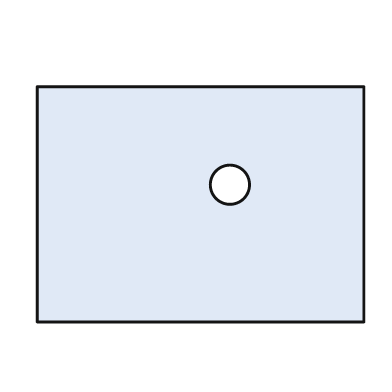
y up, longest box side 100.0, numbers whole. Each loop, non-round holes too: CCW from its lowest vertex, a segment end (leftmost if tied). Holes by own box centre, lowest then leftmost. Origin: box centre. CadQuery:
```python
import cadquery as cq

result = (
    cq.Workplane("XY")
    .moveTo(-50.0, -36.0)
    .lineTo(50.0, -36.0)
    .lineTo(50.0, 36.0)
    .lineTo(-50.0, 36.0)
    .close()
    .moveTo(9.0, 6.0)
    .circle(6.0)
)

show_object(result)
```